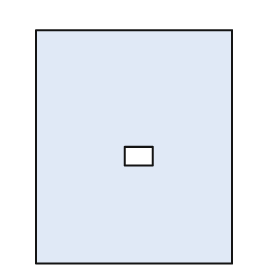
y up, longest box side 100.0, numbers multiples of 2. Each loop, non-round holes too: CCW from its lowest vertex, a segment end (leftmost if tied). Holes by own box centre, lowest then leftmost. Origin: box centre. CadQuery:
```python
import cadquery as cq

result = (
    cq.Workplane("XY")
    .moveTo(-42.0, -50.0)
    .lineTo(42.0, -50.0)
    .lineTo(42.0, 50.0)
    .lineTo(-42.0, 50.0)
    .close()
    .moveTo(-4.0, -8.0)
    .lineTo(8.0, -8.0)
    .lineTo(8.0, 0.0)
    .lineTo(-4.0, 0.0)
    .close()
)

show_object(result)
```